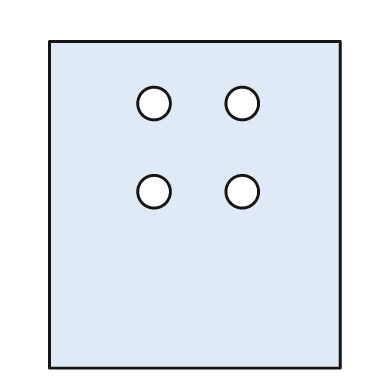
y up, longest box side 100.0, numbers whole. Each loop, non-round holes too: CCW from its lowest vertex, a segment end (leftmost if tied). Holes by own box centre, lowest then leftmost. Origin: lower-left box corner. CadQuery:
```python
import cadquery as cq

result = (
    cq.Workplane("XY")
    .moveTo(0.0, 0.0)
    .lineTo(89.0, 0.0)
    .lineTo(89.0, 100.0)
    .lineTo(0.0, 100.0)
    .close()
    .moveTo(32.0, 54.0)
    .circle(5.0)
    .moveTo(59.0, 54.0)
    .circle(5.0)
    .moveTo(32.0, 81.0)
    .circle(5.0)
    .moveTo(59.0, 81.0)
    .circle(5.0)
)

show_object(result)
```